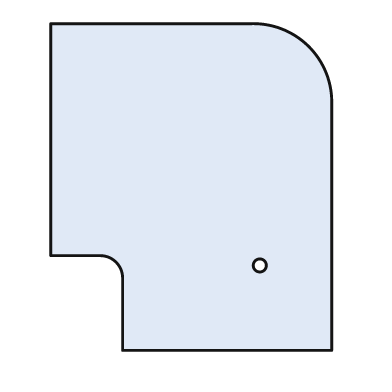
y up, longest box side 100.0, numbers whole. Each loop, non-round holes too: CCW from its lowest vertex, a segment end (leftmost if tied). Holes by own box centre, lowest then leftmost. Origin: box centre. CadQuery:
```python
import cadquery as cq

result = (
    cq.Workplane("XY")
    .moveTo(-21.0, -50.0)
    .lineTo(43.0, -50.0)
    .lineTo(43.0, 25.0)
    .threePointArc((36.0, 43.0), (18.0, 50.0))
    .lineTo(-43.0, 50.0)
    .lineTo(-43.0, -21.0)
    .lineTo(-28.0, -21.0)
    .threePointArc((-23.0, -23.0), (-21.0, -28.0))
    .close()
    .moveTo(21.0, -24.0)
    .circle(2.0)
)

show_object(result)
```